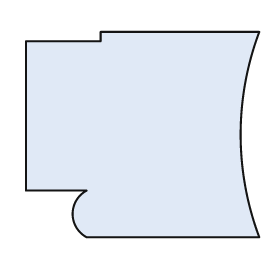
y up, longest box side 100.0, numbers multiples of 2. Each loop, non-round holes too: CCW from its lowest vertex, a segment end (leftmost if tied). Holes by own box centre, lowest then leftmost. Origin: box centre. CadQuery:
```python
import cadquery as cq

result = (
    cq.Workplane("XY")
    .moveTo(-24.0, -44.0)
    .lineTo(50.0, -44.0)
    .threePointArc((42.0, 0.0), (50.0, 44.0))
    .lineTo(-18.0, 44.0)
    .lineTo(-18.0, 40.0)
    .lineTo(-50.0, 40.0)
    .lineTo(-50.0, -24.0)
    .lineTo(-24.0, -24.0)
    .threePointArc((-30.0, -34.0), (-24.0, -44.0))
    .close()
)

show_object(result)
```